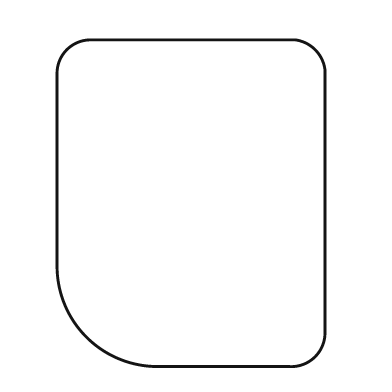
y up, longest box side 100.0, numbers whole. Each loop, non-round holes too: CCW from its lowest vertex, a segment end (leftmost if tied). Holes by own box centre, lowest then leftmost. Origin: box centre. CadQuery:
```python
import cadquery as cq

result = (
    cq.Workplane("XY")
    .moveTo(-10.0, -50.0)
    .lineTo(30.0, -50.0)
    .threePointArc((38.0, -47.0), (41.0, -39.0))
    .lineTo(41.0, 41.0)
    .threePointArc((38.0, 47.0), (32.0, 50.0))
    .lineTo(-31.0, 50.0)
    .threePointArc((-38.0, 47.0), (-41.0, 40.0))
    .lineTo(-41.0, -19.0)
    .threePointArc((-32.0, -41.0), (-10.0, -50.0))
    .close()
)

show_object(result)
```